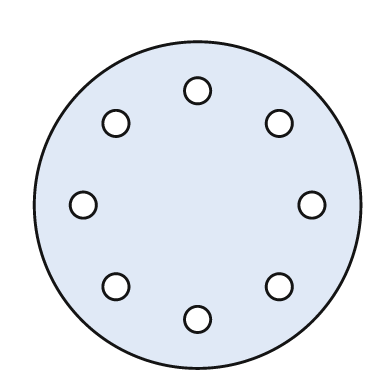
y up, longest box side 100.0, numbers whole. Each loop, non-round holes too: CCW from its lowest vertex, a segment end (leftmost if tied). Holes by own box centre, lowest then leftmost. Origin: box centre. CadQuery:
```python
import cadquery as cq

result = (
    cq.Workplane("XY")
    .moveTo(0.0, 0.0)
    .circle(50.0)
    .moveTo(0.0, -35.0)
    .circle(4.0)
    .moveTo(-25.0, -25.0)
    .circle(4.0)
    .moveTo(25.0, -25.0)
    .circle(4.0)
    .moveTo(-35.0, 0.0)
    .circle(4.0)
    .moveTo(35.0, 0.0)
    .circle(4.0)
    .moveTo(-25.0, 25.0)
    .circle(4.0)
    .moveTo(25.0, 25.0)
    .circle(4.0)
    .moveTo(0.0, 35.0)
    .circle(4.0)
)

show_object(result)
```